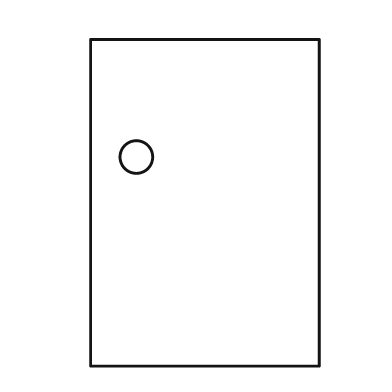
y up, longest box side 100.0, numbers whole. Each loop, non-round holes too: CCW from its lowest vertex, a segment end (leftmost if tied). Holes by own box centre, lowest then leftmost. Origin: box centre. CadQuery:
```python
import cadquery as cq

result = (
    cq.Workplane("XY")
    .moveTo(-35.0, -50.0)
    .lineTo(35.0, -50.0)
    .lineTo(35.0, 50.0)
    .lineTo(-35.0, 50.0)
    .close()
    .moveTo(-21.0, 14.0)
    .circle(5.0)
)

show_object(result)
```